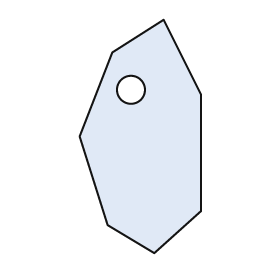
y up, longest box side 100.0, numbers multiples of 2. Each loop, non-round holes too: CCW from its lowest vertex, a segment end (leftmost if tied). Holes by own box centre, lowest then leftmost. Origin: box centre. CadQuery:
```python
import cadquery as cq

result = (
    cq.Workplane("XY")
    .moveTo(6.0, -50.0)
    .lineTo(26.0, -32.0)
    .lineTo(26.0, 18.0)
    .lineTo(10.0, 50.0)
    .lineTo(-12.0, 36.0)
    .lineTo(-26.0, 0.0)
    .lineTo(-14.0, -38.0)
    .close()
    .moveTo(-4.0, 20.0)
    .circle(6.0)
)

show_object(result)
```